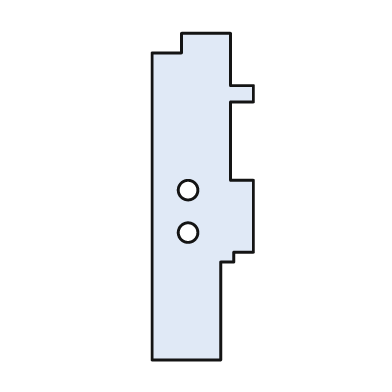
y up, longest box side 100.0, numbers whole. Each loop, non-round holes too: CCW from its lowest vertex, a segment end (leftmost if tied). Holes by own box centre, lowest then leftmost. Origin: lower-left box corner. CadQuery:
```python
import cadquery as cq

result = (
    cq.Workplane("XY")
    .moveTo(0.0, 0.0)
    .lineTo(21.0, 0.0)
    .lineTo(21.0, 30.0)
    .lineTo(25.0, 30.0)
    .lineTo(25.0, 33.0)
    .lineTo(31.0, 33.0)
    .lineTo(31.0, 55.0)
    .lineTo(24.0, 55.0)
    .lineTo(24.0, 79.0)
    .lineTo(31.0, 79.0)
    .lineTo(31.0, 84.0)
    .lineTo(24.0, 84.0)
    .lineTo(24.0, 100.0)
    .lineTo(9.0, 100.0)
    .lineTo(9.0, 94.0)
    .lineTo(0.0, 94.0)
    .close()
    .moveTo(11.0, 39.0)
    .circle(3.0)
    .moveTo(11.0, 52.0)
    .circle(3.0)
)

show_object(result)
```